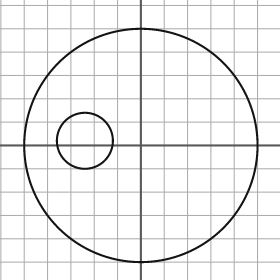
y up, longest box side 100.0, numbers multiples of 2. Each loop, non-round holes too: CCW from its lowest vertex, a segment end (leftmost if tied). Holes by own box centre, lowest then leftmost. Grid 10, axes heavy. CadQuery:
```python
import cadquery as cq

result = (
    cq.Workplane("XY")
    .moveTo(0.0, 0.0)
    .circle(50.0)
    .moveTo(-24.0, 2.0)
    .circle(12.0)
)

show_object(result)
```